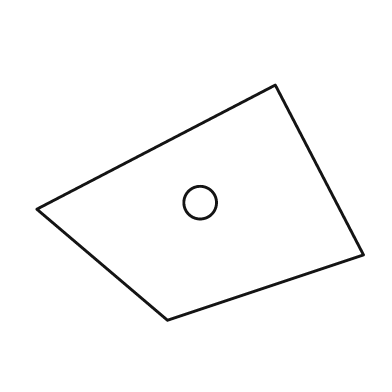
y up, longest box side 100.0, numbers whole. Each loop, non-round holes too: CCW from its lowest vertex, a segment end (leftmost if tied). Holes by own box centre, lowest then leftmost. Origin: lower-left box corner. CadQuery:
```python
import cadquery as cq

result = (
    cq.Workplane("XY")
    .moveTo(40.0, 0.0)
    .lineTo(100.0, 20.0)
    .lineTo(73.0, 72.0)
    .lineTo(0.0, 34.0)
    .close()
    .moveTo(50.0, 36.0)
    .circle(5.0)
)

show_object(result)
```